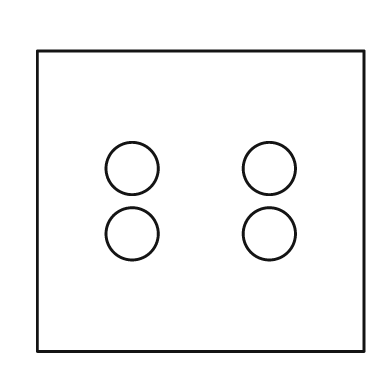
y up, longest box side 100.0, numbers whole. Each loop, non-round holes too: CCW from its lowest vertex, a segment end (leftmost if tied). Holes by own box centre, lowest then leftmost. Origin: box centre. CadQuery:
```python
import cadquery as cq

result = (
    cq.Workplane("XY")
    .moveTo(-50.0, -46.0)
    .lineTo(50.0, -46.0)
    .lineTo(50.0, 46.0)
    .lineTo(-50.0, 46.0)
    .close()
    .moveTo(-21.0, -10.0)
    .circle(8.0)
    .moveTo(21.0, -10.0)
    .circle(8.0)
    .moveTo(-21.0, 10.0)
    .circle(8.0)
    .moveTo(21.0, 10.0)
    .circle(8.0)
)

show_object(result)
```